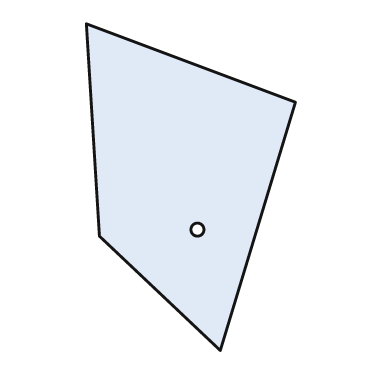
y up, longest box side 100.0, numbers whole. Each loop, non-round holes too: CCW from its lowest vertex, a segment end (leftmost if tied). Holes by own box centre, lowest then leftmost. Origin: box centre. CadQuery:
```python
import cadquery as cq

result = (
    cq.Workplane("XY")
    .moveTo(9.0, -50.0)
    .lineTo(32.0, 26.0)
    .lineTo(-32.0, 50.0)
    .lineTo(-28.0, -15.0)
    .close()
    .moveTo(2.0, -13.0)
    .circle(2.0)
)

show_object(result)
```